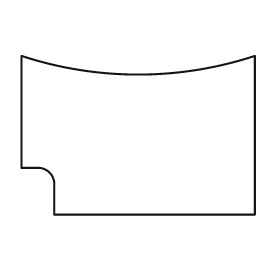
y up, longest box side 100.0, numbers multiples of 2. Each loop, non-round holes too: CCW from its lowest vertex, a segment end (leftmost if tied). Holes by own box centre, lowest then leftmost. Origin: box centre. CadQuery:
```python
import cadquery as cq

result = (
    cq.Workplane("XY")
    .moveTo(-36.0, -34.0)
    .lineTo(50.0, -34.0)
    .lineTo(50.0, 34.0)
    .threePointArc((0.0, 26.0), (-50.0, 34.0))
    .lineTo(-50.0, -14.0)
    .lineTo(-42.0, -14.0)
    .threePointArc((-38.0, -16.0), (-36.0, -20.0))
    .close()
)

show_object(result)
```